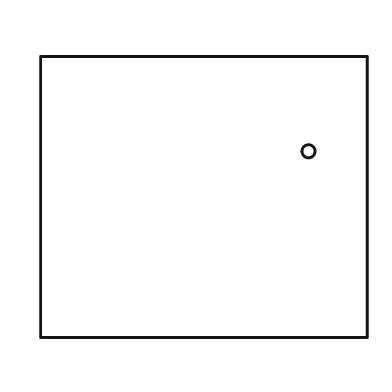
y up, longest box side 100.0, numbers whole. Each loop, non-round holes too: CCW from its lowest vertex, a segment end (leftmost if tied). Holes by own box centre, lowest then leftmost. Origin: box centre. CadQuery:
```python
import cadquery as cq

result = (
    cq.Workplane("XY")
    .moveTo(-50.0, -43.0)
    .lineTo(50.0, -43.0)
    .lineTo(50.0, 43.0)
    .lineTo(-50.0, 43.0)
    .close()
    .moveTo(32.0, 14.0)
    .circle(2.0)
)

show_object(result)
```